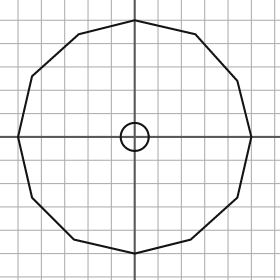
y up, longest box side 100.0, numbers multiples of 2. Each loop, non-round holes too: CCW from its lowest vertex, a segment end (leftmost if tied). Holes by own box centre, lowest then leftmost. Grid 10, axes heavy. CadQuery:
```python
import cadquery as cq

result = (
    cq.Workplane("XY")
    .moveTo(0.0, -50.0)
    .lineTo(24.0, -44.0)
    .lineTo(44.0, -26.0)
    .lineTo(50.0, 0.0)
    .lineTo(44.0, 24.0)
    .lineTo(26.0, 44.0)
    .lineTo(0.0, 50.0)
    .lineTo(-24.0, 44.0)
    .lineTo(-44.0, 26.0)
    .lineTo(-50.0, 0.0)
    .lineTo(-44.0, -26.0)
    .lineTo(-26.0, -44.0)
    .close()
    .moveTo(0.0, 0.0)
    .circle(6.0)
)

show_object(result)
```